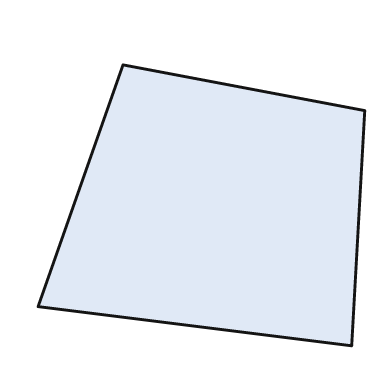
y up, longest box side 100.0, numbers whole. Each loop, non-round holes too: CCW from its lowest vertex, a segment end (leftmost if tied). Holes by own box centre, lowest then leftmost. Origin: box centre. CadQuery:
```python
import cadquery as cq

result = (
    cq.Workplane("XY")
    .moveTo(46.0, -43.0)
    .lineTo(50.0, 29.0)
    .lineTo(-24.0, 43.0)
    .lineTo(-50.0, -31.0)
    .close()
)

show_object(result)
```